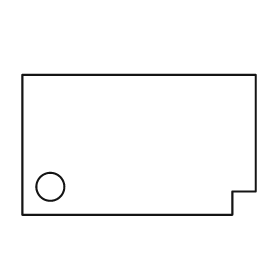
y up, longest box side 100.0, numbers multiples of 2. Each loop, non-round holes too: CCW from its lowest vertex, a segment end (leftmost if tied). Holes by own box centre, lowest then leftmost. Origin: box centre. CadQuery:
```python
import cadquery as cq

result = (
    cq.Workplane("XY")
    .moveTo(-50.0, -30.0)
    .lineTo(40.0, -30.0)
    .lineTo(40.0, -20.0)
    .lineTo(50.0, -20.0)
    .lineTo(50.0, 30.0)
    .lineTo(-50.0, 30.0)
    .close()
    .moveTo(-38.0, -18.0)
    .circle(6.0)
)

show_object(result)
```